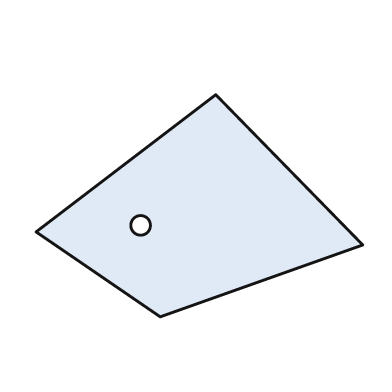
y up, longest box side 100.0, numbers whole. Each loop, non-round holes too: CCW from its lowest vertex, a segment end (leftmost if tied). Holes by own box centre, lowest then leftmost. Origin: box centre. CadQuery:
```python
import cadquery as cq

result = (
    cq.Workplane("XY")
    .moveTo(-12.0, -34.0)
    .lineTo(50.0, -12.0)
    .lineTo(5.0, 34.0)
    .lineTo(-50.0, -8.0)
    .close()
    .moveTo(-18.0, -6.0)
    .circle(3.0)
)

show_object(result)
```